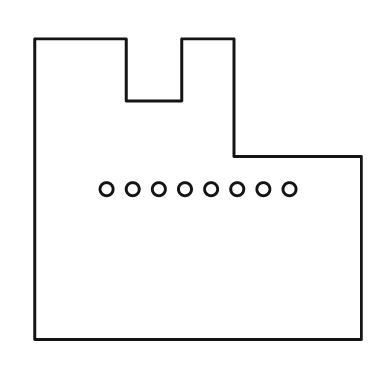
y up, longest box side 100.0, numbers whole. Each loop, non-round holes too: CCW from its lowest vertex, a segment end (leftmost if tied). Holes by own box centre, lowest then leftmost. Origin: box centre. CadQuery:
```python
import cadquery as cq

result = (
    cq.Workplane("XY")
    .moveTo(-50.0, -46.0)
    .lineTo(50.0, -46.0)
    .lineTo(50.0, 10.0)
    .lineTo(11.0, 10.0)
    .lineTo(11.0, 46.0)
    .lineTo(-5.0, 46.0)
    .lineTo(-5.0, 27.0)
    .lineTo(-22.0, 27.0)
    .lineTo(-22.0, 46.0)
    .lineTo(-50.0, 46.0)
    .close()
    .moveTo(-28.0, 0.0)
    .circle(2.0)
    .moveTo(-20.0, 0.0)
    .circle(2.0)
    .moveTo(-12.0, 0.0)
    .circle(2.0)
    .moveTo(-4.0, 0.0)
    .circle(2.0)
    .moveTo(4.0, 0.0)
    .circle(2.0)
    .moveTo(12.0, 0.0)
    .circle(2.0)
    .moveTo(20.0, 0.0)
    .circle(2.0)
    .moveTo(28.0, 0.0)
    .circle(2.0)
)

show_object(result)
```